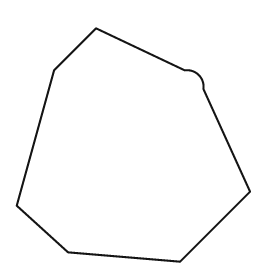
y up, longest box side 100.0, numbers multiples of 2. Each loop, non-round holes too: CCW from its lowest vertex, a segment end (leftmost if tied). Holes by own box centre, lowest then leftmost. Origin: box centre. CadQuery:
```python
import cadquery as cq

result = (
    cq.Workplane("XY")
    .moveTo(20.0, -50.0)
    .lineTo(50.0, -20.0)
    .lineTo(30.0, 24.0)
    .threePointArc((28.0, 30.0), (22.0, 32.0))
    .lineTo(-16.0, 50.0)
    .lineTo(-34.0, 32.0)
    .lineTo(-50.0, -26.0)
    .lineTo(-28.0, -46.0)
    .close()
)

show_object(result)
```